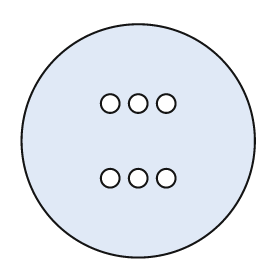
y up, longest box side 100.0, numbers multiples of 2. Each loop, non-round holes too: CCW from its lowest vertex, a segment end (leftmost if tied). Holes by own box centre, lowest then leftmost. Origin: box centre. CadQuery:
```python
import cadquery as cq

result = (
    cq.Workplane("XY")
    .moveTo(0.0, 0.0)
    .circle(50.0)
    .moveTo(-12.0, -16.0)
    .circle(4.0)
    .moveTo(0.0, -16.0)
    .circle(4.0)
    .moveTo(12.0, -16.0)
    .circle(4.0)
    .moveTo(-12.0, 16.0)
    .circle(4.0)
    .moveTo(0.0, 16.0)
    .circle(4.0)
    .moveTo(12.0, 16.0)
    .circle(4.0)
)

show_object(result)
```